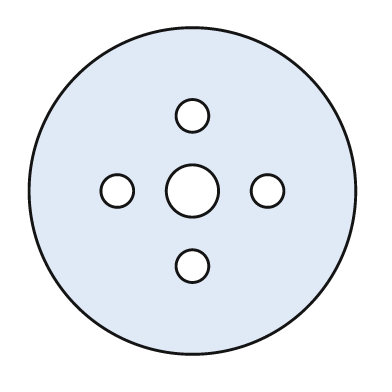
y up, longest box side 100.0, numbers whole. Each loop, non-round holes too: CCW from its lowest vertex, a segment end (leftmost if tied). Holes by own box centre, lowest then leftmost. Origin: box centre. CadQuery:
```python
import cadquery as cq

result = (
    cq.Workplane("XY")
    .moveTo(0.0, 0.0)
    .circle(50.0)
    .moveTo(0.0, -23.0)
    .circle(5.0)
    .moveTo(-23.0, 0.0)
    .circle(5.0)
    .moveTo(0.0, 0.0)
    .circle(8.0)
    .moveTo(23.0, 0.0)
    .circle(5.0)
    .moveTo(0.0, 23.0)
    .circle(5.0)
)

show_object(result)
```